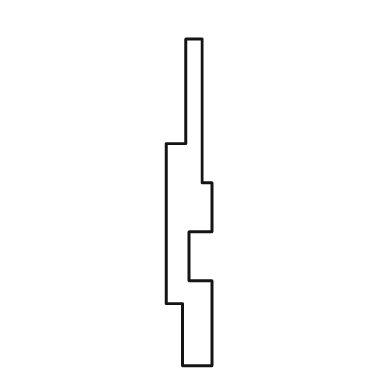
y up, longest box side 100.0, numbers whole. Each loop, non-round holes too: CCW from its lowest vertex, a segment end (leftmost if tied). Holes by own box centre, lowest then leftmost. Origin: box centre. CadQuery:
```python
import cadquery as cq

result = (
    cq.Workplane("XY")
    .moveTo(-2.0, -50.0)
    .lineTo(7.0, -50.0)
    .lineTo(7.0, -24.0)
    .lineTo(0.0, -24.0)
    .lineTo(0.0, -9.0)
    .lineTo(7.0, -9.0)
    .lineTo(7.0, 6.0)
    .lineTo(4.0, 6.0)
    .lineTo(4.0, 50.0)
    .lineTo(-1.0, 50.0)
    .lineTo(-1.0, 18.0)
    .lineTo(-7.0, 18.0)
    .lineTo(-7.0, -31.0)
    .lineTo(-2.0, -31.0)
    .close()
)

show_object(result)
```